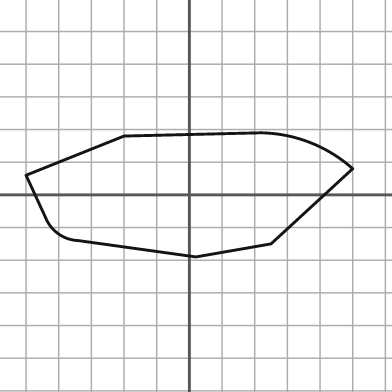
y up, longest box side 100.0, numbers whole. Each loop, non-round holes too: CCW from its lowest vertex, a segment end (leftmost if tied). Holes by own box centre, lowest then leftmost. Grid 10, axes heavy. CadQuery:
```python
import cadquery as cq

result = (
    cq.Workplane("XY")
    .moveTo(2.0, -19.0)
    .lineTo(25.0, -15.0)
    .lineTo(50.0, 8.0)
    .threePointArc((37.0, 16.0), (22.0, 19.0))
    .lineTo(-20.0, 18.0)
    .lineTo(-50.0, 6.0)
    .lineTo(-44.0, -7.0)
    .threePointArc((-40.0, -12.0), (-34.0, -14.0))
    .close()
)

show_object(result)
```